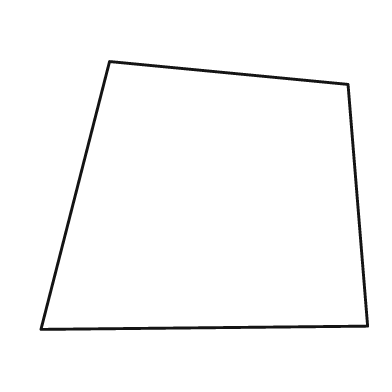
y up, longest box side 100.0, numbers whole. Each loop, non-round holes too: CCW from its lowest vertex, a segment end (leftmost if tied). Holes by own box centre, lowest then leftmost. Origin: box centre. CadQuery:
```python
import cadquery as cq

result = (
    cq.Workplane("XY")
    .moveTo(-50.0, -41.0)
    .lineTo(50.0, -40.0)
    .lineTo(44.0, 34.0)
    .lineTo(-29.0, 41.0)
    .close()
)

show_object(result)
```